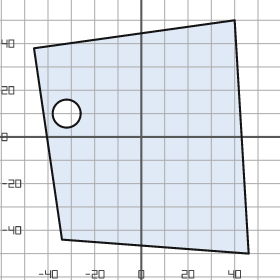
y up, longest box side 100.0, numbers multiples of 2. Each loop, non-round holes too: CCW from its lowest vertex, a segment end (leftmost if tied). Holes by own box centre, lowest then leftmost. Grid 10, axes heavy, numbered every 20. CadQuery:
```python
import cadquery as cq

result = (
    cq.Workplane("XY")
    .moveTo(46.0, -50.0)
    .lineTo(40.0, 50.0)
    .lineTo(-46.0, 38.0)
    .lineTo(-34.0, -44.0)
    .close()
    .moveTo(-32.0, 10.0)
    .circle(6.0)
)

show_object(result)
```